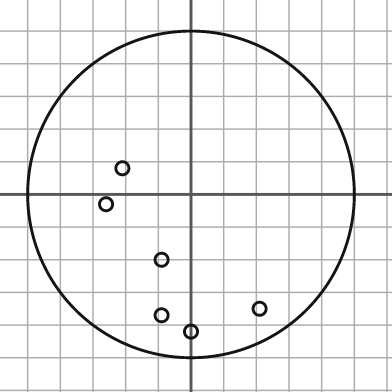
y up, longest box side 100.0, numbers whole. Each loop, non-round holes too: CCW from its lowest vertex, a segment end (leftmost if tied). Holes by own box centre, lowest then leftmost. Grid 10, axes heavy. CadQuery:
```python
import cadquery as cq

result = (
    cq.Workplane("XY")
    .moveTo(0.0, 0.0)
    .circle(50.0)
    .moveTo(0.0, -42.0)
    .circle(2.0)
    .moveTo(-9.0, -37.0)
    .circle(2.0)
    .moveTo(21.0, -35.0)
    .circle(2.0)
    .moveTo(-9.0, -20.0)
    .circle(2.0)
    .moveTo(-26.0, -3.0)
    .circle(2.0)
    .moveTo(-21.0, 8.0)
    .circle(2.0)
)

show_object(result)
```